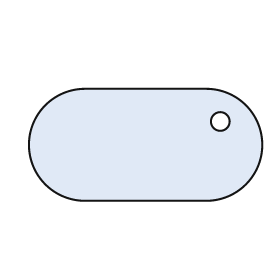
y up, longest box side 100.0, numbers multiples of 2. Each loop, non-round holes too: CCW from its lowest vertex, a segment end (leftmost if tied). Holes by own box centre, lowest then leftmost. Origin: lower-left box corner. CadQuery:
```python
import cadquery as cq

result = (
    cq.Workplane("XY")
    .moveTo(24.0, 0.0)
    .lineTo(76.0, 0.0)
    .threePointArc((100.0, 24.0), (76.0, 48.0))
    .lineTo(24.0, 48.0)
    .threePointArc((0.0, 24.0), (24.0, 0.0))
    .close()
    .moveTo(82.0, 34.0)
    .circle(4.0)
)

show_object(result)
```